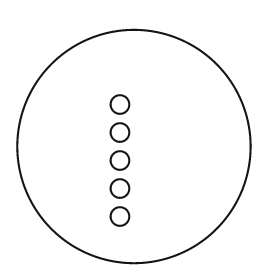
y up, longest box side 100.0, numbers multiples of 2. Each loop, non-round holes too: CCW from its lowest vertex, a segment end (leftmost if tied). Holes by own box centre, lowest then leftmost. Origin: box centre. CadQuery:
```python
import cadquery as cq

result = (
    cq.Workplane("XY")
    .moveTo(0.0, 0.0)
    .circle(50.0)
    .moveTo(-6.0, -30.0)
    .circle(4.0)
    .moveTo(-6.0, -18.0)
    .circle(4.0)
    .moveTo(-6.0, -6.0)
    .circle(4.0)
    .moveTo(-6.0, 6.0)
    .circle(4.0)
    .moveTo(-6.0, 18.0)
    .circle(4.0)
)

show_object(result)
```